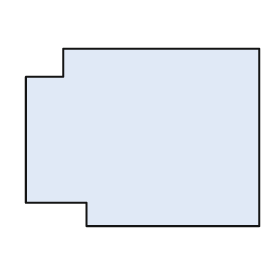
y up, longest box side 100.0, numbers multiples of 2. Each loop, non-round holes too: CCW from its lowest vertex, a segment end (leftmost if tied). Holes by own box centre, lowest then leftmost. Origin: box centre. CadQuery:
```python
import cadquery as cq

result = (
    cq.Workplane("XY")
    .moveTo(-24.0, -38.0)
    .lineTo(50.0, -38.0)
    .lineTo(50.0, 38.0)
    .lineTo(-34.0, 38.0)
    .lineTo(-34.0, 26.0)
    .lineTo(-50.0, 26.0)
    .lineTo(-50.0, -28.0)
    .lineTo(-24.0, -28.0)
    .close()
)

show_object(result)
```